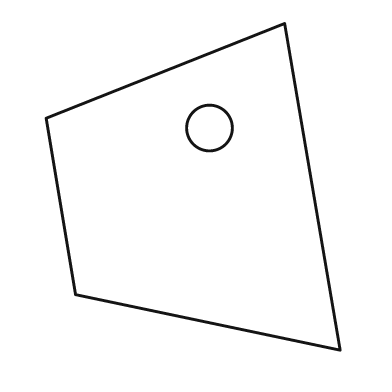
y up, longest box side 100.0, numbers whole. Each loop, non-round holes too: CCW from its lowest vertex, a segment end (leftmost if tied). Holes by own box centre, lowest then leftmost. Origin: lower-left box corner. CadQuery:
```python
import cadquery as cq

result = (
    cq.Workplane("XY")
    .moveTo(90.0, 0.0)
    .lineTo(73.0, 100.0)
    .lineTo(0.0, 71.0)
    .lineTo(9.0, 17.0)
    .close()
    .moveTo(50.0, 68.0)
    .circle(7.0)
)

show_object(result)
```